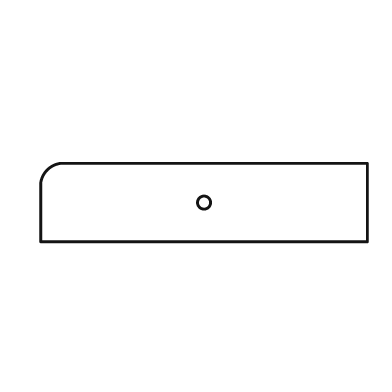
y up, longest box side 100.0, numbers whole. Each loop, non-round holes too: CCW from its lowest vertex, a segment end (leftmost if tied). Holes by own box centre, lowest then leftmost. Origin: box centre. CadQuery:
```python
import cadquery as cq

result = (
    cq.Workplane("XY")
    .moveTo(-50.0, -12.0)
    .lineTo(50.0, -12.0)
    .lineTo(50.0, 12.0)
    .lineTo(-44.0, 12.0)
    .threePointArc((-48.0, 10.0), (-50.0, 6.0))
    .close()
    .moveTo(0.0, 0.0)
    .circle(2.0)
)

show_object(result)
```